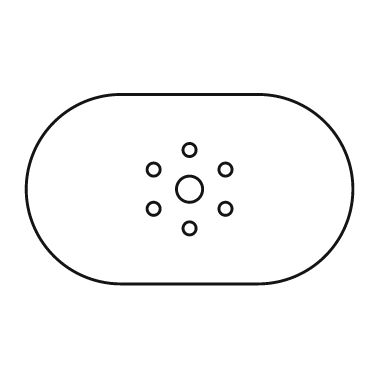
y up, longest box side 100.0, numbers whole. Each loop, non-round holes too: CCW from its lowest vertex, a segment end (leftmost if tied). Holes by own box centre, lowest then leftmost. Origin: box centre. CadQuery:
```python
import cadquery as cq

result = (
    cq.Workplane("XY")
    .moveTo(-21.0, -29.0)
    .lineTo(21.0, -29.0)
    .threePointArc((50.0, 0.0), (21.0, 29.0))
    .lineTo(-21.0, 29.0)
    .threePointArc((-50.0, 0.0), (-21.0, -29.0))
    .close()
    .moveTo(0.0, -12.0)
    .circle(2.0)
    .moveTo(-11.0, -6.0)
    .circle(2.0)
    .moveTo(11.0, -6.0)
    .circle(2.0)
    .moveTo(0.0, 0.0)
    .circle(4.0)
    .moveTo(-11.0, 6.0)
    .circle(2.0)
    .moveTo(11.0, 6.0)
    .circle(2.0)
    .moveTo(0.0, 12.0)
    .circle(2.0)
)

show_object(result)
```